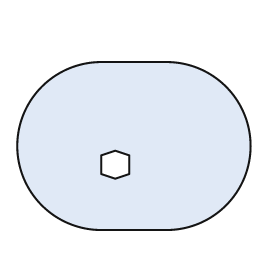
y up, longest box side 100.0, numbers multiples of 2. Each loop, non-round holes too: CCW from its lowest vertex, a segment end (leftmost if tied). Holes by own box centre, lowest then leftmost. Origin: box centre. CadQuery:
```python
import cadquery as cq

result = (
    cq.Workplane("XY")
    .moveTo(-14.0, -36.0)
    .lineTo(14.0, -36.0)
    .threePointArc((50.0, 0.0), (14.0, 36.0))
    .lineTo(-14.0, 36.0)
    .threePointArc((-50.0, 0.0), (-14.0, -36.0))
    .close()
    .moveTo(-8.0, -14.0)
    .lineTo(-2.0, -12.0)
    .lineTo(-2.0, -4.0)
    .lineTo(-8.0, -2.0)
    .lineTo(-14.0, -4.0)
    .lineTo(-14.0, -12.0)
    .close()
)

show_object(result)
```